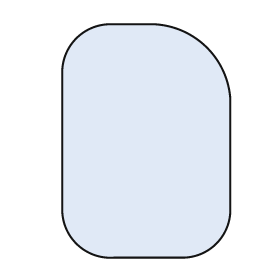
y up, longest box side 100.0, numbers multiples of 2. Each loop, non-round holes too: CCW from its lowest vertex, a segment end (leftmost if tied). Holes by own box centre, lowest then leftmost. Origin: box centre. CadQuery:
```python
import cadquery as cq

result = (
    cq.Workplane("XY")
    .moveTo(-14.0, -50.0)
    .lineTo(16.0, -50.0)
    .threePointArc((30.0, -44.0), (36.0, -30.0))
    .lineTo(36.0, 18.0)
    .threePointArc((26.0, 40.0), (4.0, 50.0))
    .lineTo(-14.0, 50.0)
    .threePointArc((-30.0, 44.0), (-36.0, 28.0))
    .lineTo(-36.0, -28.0)
    .threePointArc((-30.0, -44.0), (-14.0, -50.0))
    .close()
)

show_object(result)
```